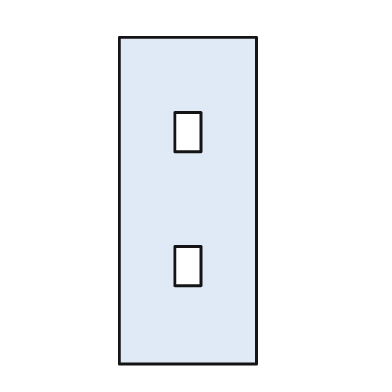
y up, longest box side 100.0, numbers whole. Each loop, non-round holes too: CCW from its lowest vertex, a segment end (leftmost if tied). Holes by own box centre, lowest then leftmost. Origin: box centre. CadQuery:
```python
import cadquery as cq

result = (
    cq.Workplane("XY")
    .moveTo(-21.0, -50.0)
    .lineTo(21.0, -50.0)
    .lineTo(21.0, 50.0)
    .lineTo(-21.0, 50.0)
    .close()
    .moveTo(-4.0, -26.0)
    .lineTo(4.0, -26.0)
    .lineTo(4.0, -14.0)
    .lineTo(-4.0, -14.0)
    .close()
    .moveTo(-4.0, 15.0)
    .lineTo(4.0, 15.0)
    .lineTo(4.0, 27.0)
    .lineTo(-4.0, 27.0)
    .close()
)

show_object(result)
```